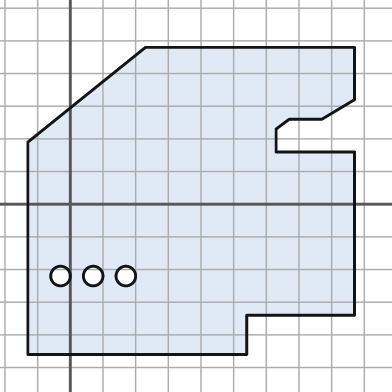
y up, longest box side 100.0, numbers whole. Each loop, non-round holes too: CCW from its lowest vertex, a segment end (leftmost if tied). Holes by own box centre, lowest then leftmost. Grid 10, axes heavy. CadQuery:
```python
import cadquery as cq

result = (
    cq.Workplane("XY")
    .moveTo(-13.0, -46.0)
    .lineTo(54.0, -46.0)
    .lineTo(54.0, -34.0)
    .lineTo(87.0, -34.0)
    .lineTo(87.0, 16.0)
    .lineTo(63.0, 16.0)
    .lineTo(63.0, 23.0)
    .lineTo(67.0, 26.0)
    .lineTo(77.0, 26.0)
    .lineTo(87.0, 32.0)
    .lineTo(87.0, 48.0)
    .lineTo(23.0, 48.0)
    .lineTo(-13.0, 19.0)
    .close()
    .moveTo(-3.0, -22.0)
    .circle(3.0)
    .moveTo(7.0, -22.0)
    .circle(3.0)
    .moveTo(17.0, -22.0)
    .circle(3.0)
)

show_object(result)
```